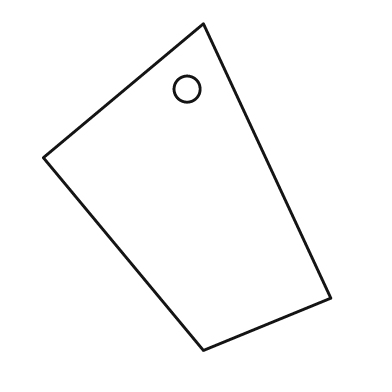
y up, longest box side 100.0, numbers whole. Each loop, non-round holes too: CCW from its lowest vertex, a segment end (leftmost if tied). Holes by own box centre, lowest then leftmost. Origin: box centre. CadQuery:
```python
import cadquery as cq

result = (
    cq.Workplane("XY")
    .moveTo(5.0, -50.0)
    .lineTo(44.0, -34.0)
    .lineTo(5.0, 50.0)
    .lineTo(-44.0, 9.0)
    .close()
    .moveTo(0.0, 30.0)
    .circle(4.0)
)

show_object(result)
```